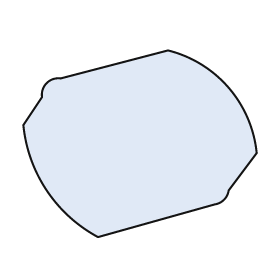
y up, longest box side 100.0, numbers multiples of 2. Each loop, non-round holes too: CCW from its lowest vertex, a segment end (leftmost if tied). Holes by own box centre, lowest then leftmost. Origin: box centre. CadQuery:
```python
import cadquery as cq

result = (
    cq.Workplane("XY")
    .moveTo(-18.0, -40.0)
    .lineTo(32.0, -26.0)
    .threePointArc((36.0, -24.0), (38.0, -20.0))
    .lineTo(50.0, -4.0)
    .threePointArc((38.0, 24.0), (12.0, 40.0))
    .lineTo(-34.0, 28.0)
    .threePointArc((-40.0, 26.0), (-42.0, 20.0))
    .lineTo(-50.0, 8.0)
    .threePointArc((-40.0, -20.0), (-18.0, -40.0))
    .close()
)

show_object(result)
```